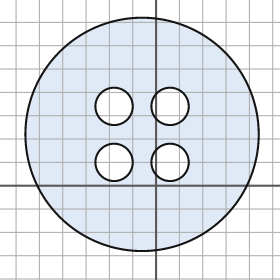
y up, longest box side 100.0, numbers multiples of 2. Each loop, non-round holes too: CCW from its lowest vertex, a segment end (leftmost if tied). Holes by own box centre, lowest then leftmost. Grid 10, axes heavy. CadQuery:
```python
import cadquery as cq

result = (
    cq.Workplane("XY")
    .moveTo(-6.0, 22.0)
    .circle(50.0)
    .moveTo(-18.0, 10.0)
    .circle(8.0)
    .moveTo(6.0, 10.0)
    .circle(8.0)
    .moveTo(-18.0, 34.0)
    .circle(8.0)
    .moveTo(6.0, 34.0)
    .circle(8.0)
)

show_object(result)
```